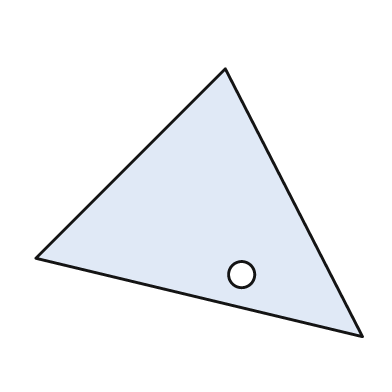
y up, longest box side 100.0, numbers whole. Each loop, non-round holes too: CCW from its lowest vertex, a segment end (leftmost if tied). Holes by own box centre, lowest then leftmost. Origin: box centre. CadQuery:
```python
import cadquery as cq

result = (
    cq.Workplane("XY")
    .moveTo(50.0, -41.0)
    .lineTo(8.0, 41.0)
    .lineTo(-50.0, -17.0)
    .close()
    .moveTo(13.0, -22.0)
    .circle(4.0)
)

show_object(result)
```